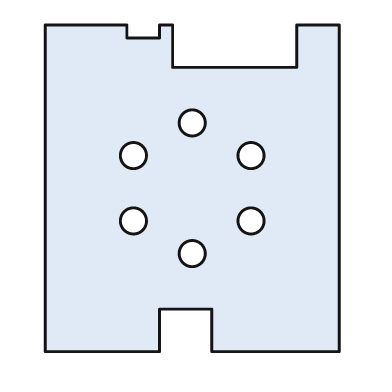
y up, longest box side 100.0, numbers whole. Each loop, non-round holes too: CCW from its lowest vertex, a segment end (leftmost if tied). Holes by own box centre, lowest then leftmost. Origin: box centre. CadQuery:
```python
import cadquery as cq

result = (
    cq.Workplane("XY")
    .moveTo(-45.0, -50.0)
    .lineTo(-10.0, -50.0)
    .lineTo(-10.0, -37.0)
    .lineTo(6.0, -37.0)
    .lineTo(6.0, -50.0)
    .lineTo(45.0, -50.0)
    .lineTo(45.0, 50.0)
    .lineTo(32.0, 50.0)
    .lineTo(32.0, 37.0)
    .lineTo(-6.0, 37.0)
    .lineTo(-6.0, 50.0)
    .lineTo(-10.0, 50.0)
    .lineTo(-10.0, 46.0)
    .lineTo(-20.0, 46.0)
    .lineTo(-20.0, 50.0)
    .lineTo(-45.0, 50.0)
    .close()
    .moveTo(0.0, -20.0)
    .circle(4.0)
    .moveTo(-18.0, -10.0)
    .circle(4.0)
    .moveTo(18.0, -10.0)
    .circle(4.0)
    .moveTo(-18.0, 10.0)
    .circle(4.0)
    .moveTo(18.0, 10.0)
    .circle(4.0)
    .moveTo(0.0, 20.0)
    .circle(4.0)
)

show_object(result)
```